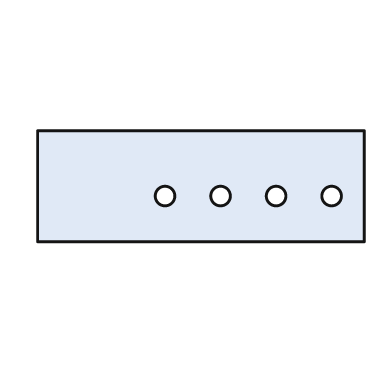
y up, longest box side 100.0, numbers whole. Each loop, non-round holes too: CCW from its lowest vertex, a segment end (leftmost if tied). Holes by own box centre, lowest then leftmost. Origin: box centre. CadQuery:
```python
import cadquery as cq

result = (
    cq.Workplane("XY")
    .moveTo(-50.0, -17.0)
    .lineTo(50.0, -17.0)
    .lineTo(50.0, 17.0)
    .lineTo(-50.0, 17.0)
    .close()
    .moveTo(-11.0, -3.0)
    .circle(3.0)
    .moveTo(6.0, -3.0)
    .circle(3.0)
    .moveTo(23.0, -3.0)
    .circle(3.0)
    .moveTo(40.0, -3.0)
    .circle(3.0)
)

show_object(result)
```